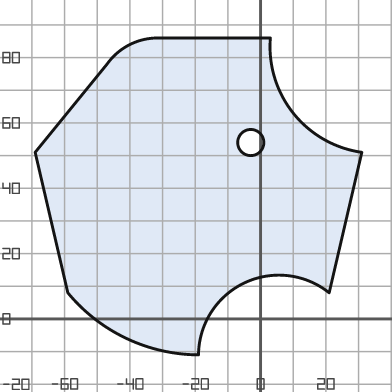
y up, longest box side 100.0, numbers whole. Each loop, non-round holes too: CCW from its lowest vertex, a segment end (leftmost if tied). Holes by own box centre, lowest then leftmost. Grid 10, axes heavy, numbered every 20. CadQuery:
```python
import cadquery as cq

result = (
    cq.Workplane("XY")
    .moveTo(-19.0, -11.0)
    .threePointArc((-5.0, 11.0), (21.0, 8.0))
    .lineTo(31.0, 51.0)
    .threePointArc((10.0, 63.0), (3.0, 86.0))
    .lineTo(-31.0, 86.0)
    .threePointArc((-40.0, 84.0), (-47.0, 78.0))
    .lineTo(-69.0, 51.0)
    .lineTo(-59.0, 8.0)
    .threePointArc((-41.0, -6.0), (-19.0, -11.0))
    .close()
    .moveTo(-3.0, 54.0)
    .circle(4.0)
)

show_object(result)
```